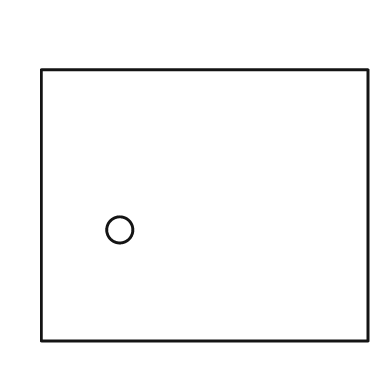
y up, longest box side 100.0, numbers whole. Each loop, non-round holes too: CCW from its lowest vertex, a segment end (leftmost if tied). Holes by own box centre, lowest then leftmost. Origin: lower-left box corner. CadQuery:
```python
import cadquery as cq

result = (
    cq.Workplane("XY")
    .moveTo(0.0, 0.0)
    .lineTo(100.0, 0.0)
    .lineTo(100.0, 83.0)
    .lineTo(0.0, 83.0)
    .close()
    .moveTo(24.0, 34.0)
    .circle(4.0)
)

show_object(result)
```